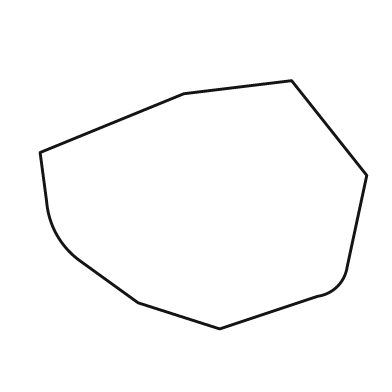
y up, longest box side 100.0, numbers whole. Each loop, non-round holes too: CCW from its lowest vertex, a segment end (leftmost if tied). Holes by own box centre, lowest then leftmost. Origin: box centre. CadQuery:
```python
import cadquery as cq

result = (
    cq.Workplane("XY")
    .moveTo(5.0, -38.0)
    .lineTo(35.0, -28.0)
    .threePointArc((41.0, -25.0), (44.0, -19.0))
    .lineTo(50.0, 9.0)
    .lineTo(27.0, 38.0)
    .lineTo(-6.0, 34.0)
    .lineTo(-50.0, 16.0)
    .lineTo(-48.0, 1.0)
    .threePointArc((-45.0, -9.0), (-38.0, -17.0))
    .lineTo(-20.0, -30.0)
    .close()
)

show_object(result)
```